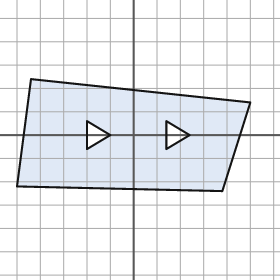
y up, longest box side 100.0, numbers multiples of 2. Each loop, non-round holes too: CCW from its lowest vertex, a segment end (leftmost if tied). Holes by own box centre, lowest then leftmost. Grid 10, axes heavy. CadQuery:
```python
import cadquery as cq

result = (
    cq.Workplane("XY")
    .moveTo(38.0, -24.0)
    .lineTo(50.0, 14.0)
    .lineTo(-44.0, 24.0)
    .lineTo(-50.0, -22.0)
    .close()
    .moveTo(-20.0, -6.0)
    .lineTo(-10.0, 0.0)
    .lineTo(-20.0, 6.0)
    .close()
    .moveTo(14.0, -6.0)
    .lineTo(24.0, 0.0)
    .lineTo(14.0, 6.0)
    .close()
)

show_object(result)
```